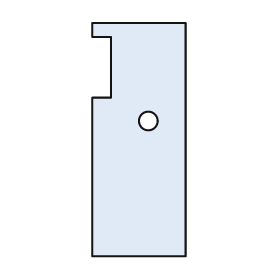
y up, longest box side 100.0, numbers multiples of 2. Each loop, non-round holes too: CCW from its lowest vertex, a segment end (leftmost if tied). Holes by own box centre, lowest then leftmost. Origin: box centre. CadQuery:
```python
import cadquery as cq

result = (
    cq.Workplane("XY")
    .moveTo(-20.0, -50.0)
    .lineTo(20.0, -50.0)
    .lineTo(20.0, 50.0)
    .lineTo(-20.0, 50.0)
    .lineTo(-20.0, 44.0)
    .lineTo(-12.0, 44.0)
    .lineTo(-12.0, 18.0)
    .lineTo(-20.0, 18.0)
    .close()
    .moveTo(4.0, 8.0)
    .circle(4.0)
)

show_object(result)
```